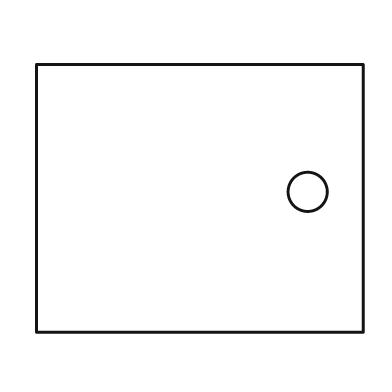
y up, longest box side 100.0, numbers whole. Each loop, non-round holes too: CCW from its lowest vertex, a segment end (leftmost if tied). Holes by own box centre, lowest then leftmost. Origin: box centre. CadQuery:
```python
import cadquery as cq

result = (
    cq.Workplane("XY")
    .moveTo(-50.0, -41.0)
    .lineTo(50.0, -41.0)
    .lineTo(50.0, 41.0)
    .lineTo(-50.0, 41.0)
    .close()
    .moveTo(33.0, 2.0)
    .circle(6.0)
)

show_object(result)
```